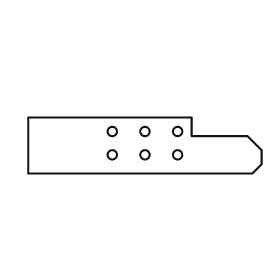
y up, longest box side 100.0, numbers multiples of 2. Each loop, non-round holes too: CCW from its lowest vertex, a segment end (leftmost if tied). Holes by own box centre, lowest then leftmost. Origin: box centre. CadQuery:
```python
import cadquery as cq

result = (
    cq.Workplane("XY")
    .moveTo(-50.0, -12.0)
    .lineTo(46.0, -12.0)
    .lineTo(50.0, -8.0)
    .lineTo(50.0, -2.0)
    .lineTo(44.0, 4.0)
    .lineTo(20.0, 4.0)
    .lineTo(20.0, 12.0)
    .lineTo(-50.0, 12.0)
    .close()
    .moveTo(-14.0, -4.0)
    .circle(2.0)
    .moveTo(0.0, -4.0)
    .circle(2.0)
    .moveTo(14.0, -4.0)
    .circle(2.0)
    .moveTo(-14.0, 6.0)
    .circle(2.0)
    .moveTo(0.0, 6.0)
    .circle(2.0)
    .moveTo(14.0, 6.0)
    .circle(2.0)
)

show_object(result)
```